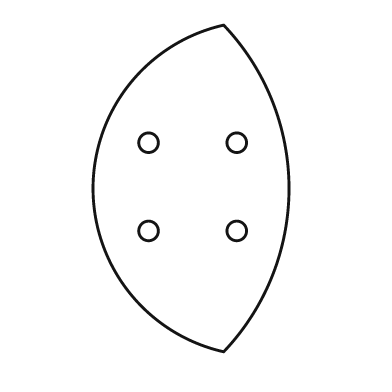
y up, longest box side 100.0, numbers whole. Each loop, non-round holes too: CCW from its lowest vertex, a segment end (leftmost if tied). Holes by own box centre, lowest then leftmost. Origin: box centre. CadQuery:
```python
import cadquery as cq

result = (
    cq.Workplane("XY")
    .moveTo(10.0, -50.0)
    .threePointArc((30.0, 0.0), (10.0, 50.0))
    .threePointArc((-30.0, 0.0), (10.0, -50.0))
    .close()
    .moveTo(-13.0, -13.0)
    .circle(3.0)
    .moveTo(14.0, -13.0)
    .circle(3.0)
    .moveTo(-13.0, 14.0)
    .circle(3.0)
    .moveTo(14.0, 14.0)
    .circle(3.0)
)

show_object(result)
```